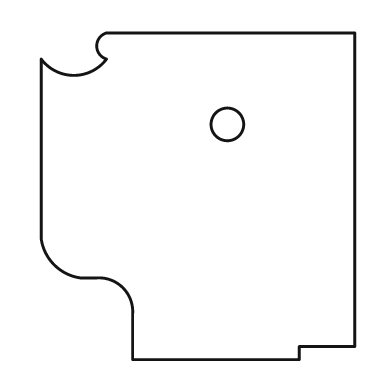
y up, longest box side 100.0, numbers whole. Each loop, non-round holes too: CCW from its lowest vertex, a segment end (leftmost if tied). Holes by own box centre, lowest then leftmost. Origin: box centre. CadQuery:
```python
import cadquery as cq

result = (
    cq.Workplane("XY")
    .moveTo(-20.0, -50.0)
    .lineTo(31.0, -50.0)
    .lineTo(31.0, -46.0)
    .lineTo(48.0, -46.0)
    .lineTo(48.0, 50.0)
    .lineTo(-28.0, 50.0)
    .threePointArc((-31.0, 46.0), (-28.0, 42.0))
    .threePointArc((-38.0, 37.0), (-48.0, 42.0))
    .lineTo(-48.0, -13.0)
    .threePointArc((-44.0, -21.0), (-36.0, -25.0))
    .lineTo(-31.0, -25.0)
    .threePointArc((-23.0, -28.0), (-20.0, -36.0))
    .close()
    .moveTo(9.0, 22.0)
    .circle(5.0)
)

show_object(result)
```